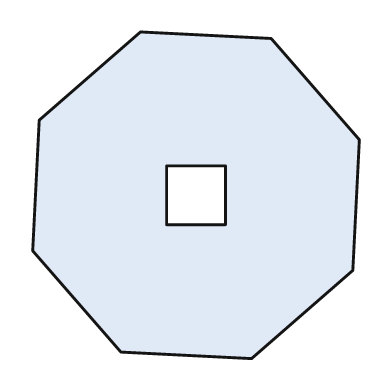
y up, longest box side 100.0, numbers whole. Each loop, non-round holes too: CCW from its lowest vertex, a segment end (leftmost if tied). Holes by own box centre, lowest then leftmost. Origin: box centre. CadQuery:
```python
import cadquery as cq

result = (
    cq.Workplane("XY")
    .moveTo(17.0, -50.0)
    .lineTo(48.0, -23.0)
    .lineTo(50.0, 17.0)
    .lineTo(23.0, 48.0)
    .lineTo(-17.0, 50.0)
    .lineTo(-48.0, 23.0)
    .lineTo(-50.0, -17.0)
    .lineTo(-23.0, -48.0)
    .close()
    .moveTo(-9.0, -9.0)
    .lineTo(9.0, -9.0)
    .lineTo(9.0, 9.0)
    .lineTo(-9.0, 9.0)
    .close()
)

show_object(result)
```